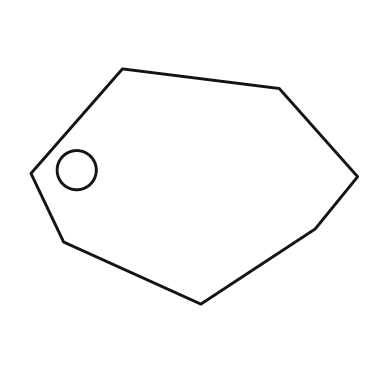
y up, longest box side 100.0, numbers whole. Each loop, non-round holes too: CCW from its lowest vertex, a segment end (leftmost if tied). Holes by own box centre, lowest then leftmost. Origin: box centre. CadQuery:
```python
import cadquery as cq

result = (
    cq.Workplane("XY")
    .moveTo(2.0, -36.0)
    .lineTo(37.0, -13.0)
    .lineTo(50.0, 3.0)
    .lineTo(26.0, 30.0)
    .lineTo(-22.0, 36.0)
    .lineTo(-50.0, 4.0)
    .lineTo(-40.0, -17.0)
    .close()
    .moveTo(-36.0, 5.0)
    .circle(6.0)
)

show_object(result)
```